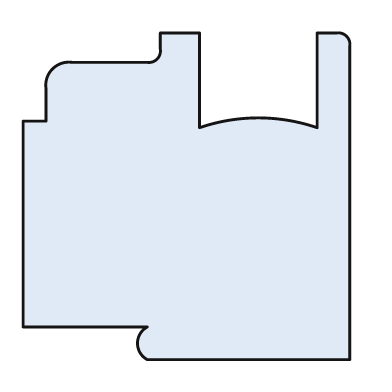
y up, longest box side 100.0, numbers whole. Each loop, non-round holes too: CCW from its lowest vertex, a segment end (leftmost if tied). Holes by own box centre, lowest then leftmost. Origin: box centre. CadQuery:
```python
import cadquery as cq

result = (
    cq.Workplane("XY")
    .moveTo(-12.0, -50.0)
    .lineTo(50.0, -50.0)
    .lineTo(50.0, 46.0)
    .threePointArc((49.0, 49.0), (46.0, 50.0))
    .lineTo(40.0, 50.0)
    .lineTo(40.0, 21.0)
    .threePointArc((22.0, 24.0), (4.0, 21.0))
    .lineTo(4.0, 50.0)
    .lineTo(-8.0, 50.0)
    .lineTo(-8.0, 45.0)
    .threePointArc((-9.0, 42.0), (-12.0, 41.0))
    .lineTo(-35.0, 41.0)
    .threePointArc((-41.0, 39.0), (-43.0, 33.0))
    .lineTo(-43.0, 23.0)
    .lineTo(-50.0, 23.0)
    .lineTo(-50.0, -40.0)
    .lineTo(-12.0, -40.0)
    .threePointArc((-15.0, -45.0), (-12.0, -50.0))
    .close()
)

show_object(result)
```